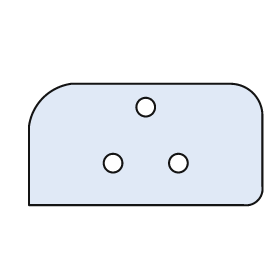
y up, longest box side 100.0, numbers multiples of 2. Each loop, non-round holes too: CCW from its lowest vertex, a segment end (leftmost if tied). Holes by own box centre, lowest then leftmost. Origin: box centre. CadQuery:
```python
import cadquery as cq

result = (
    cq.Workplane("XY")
    .moveTo(-50.0, -26.0)
    .lineTo(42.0, -26.0)
    .threePointArc((48.0, -24.0), (50.0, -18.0))
    .lineTo(50.0, 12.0)
    .threePointArc((46.0, 22.0), (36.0, 26.0))
    .lineTo(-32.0, 26.0)
    .threePointArc((-44.0, 20.0), (-50.0, 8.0))
    .close()
    .moveTo(-14.0, -8.0)
    .circle(4.0)
    .moveTo(14.0, -8.0)
    .circle(4.0)
    .moveTo(0.0, 16.0)
    .circle(4.0)
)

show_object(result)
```